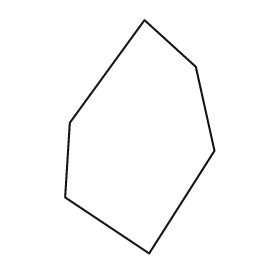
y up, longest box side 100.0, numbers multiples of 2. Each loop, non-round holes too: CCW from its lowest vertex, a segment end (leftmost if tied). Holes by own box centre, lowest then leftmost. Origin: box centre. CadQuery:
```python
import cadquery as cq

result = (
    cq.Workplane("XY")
    .moveTo(4.0, -50.0)
    .lineTo(32.0, -6.0)
    .lineTo(24.0, 30.0)
    .lineTo(2.0, 50.0)
    .lineTo(-30.0, 6.0)
    .lineTo(-32.0, -26.0)
    .close()
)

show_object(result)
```